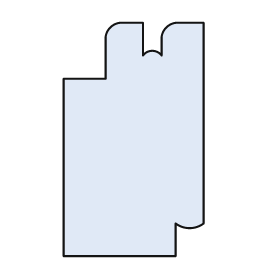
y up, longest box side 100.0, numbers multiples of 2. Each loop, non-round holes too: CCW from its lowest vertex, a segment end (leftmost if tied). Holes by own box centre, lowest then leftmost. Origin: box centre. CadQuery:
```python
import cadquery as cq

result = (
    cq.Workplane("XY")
    .moveTo(-30.0, -50.0)
    .lineTo(18.0, -50.0)
    .lineTo(18.0, -36.0)
    .threePointArc((24.0, -38.0), (30.0, -36.0))
    .lineTo(30.0, 50.0)
    .lineTo(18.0, 50.0)
    .threePointArc((14.0, 48.0), (12.0, 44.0))
    .lineTo(12.0, 36.0)
    .threePointArc((8.0, 38.0), (4.0, 36.0))
    .lineTo(4.0, 50.0)
    .lineTo(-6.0, 50.0)
    .threePointArc((-10.0, 48.0), (-12.0, 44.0))
    .lineTo(-12.0, 26.0)
    .lineTo(-30.0, 26.0)
    .close()
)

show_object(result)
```